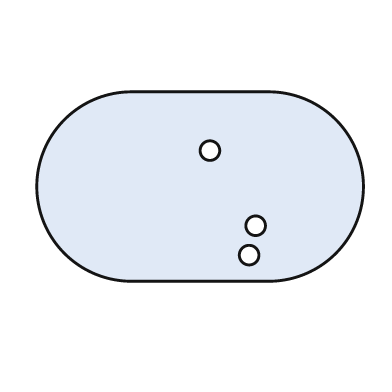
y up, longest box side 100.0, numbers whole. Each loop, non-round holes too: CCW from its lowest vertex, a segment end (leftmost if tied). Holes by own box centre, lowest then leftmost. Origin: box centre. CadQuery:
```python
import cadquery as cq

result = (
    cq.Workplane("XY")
    .moveTo(-21.0, -29.0)
    .lineTo(21.0, -29.0)
    .threePointArc((50.0, 0.0), (21.0, 29.0))
    .lineTo(-21.0, 29.0)
    .threePointArc((-50.0, 0.0), (-21.0, -29.0))
    .close()
    .moveTo(15.0, -21.0)
    .circle(3.0)
    .moveTo(17.0, -12.0)
    .circle(3.0)
    .moveTo(3.0, 11.0)
    .circle(3.0)
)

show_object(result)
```